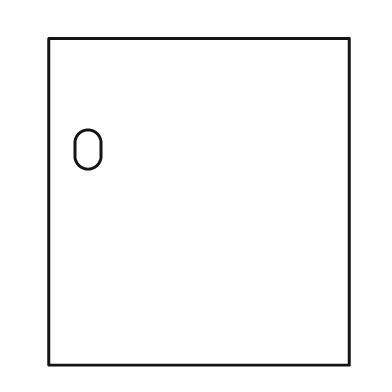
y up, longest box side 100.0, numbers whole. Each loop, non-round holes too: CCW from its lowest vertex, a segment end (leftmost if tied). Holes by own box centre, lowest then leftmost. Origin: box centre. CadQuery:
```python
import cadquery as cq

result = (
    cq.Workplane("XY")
    .moveTo(-46.0, -50.0)
    .lineTo(46.0, -50.0)
    .lineTo(46.0, 50.0)
    .lineTo(-46.0, 50.0)
    .close()
    .moveTo(-38.0, 14.0)
    .threePointArc((-34.0, 10.0), (-30.0, 14.0))
    .lineTo(-30.0, 18.0)
    .threePointArc((-34.0, 22.0), (-38.0, 18.0))
    .close()
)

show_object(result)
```